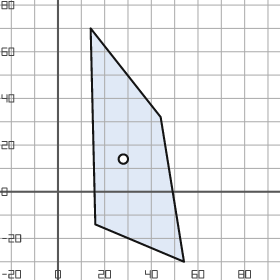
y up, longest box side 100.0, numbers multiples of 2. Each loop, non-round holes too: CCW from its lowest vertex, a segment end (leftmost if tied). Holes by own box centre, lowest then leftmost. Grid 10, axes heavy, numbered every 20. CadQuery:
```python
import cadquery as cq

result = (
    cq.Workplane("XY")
    .moveTo(54.0, -30.0)
    .lineTo(44.0, 32.0)
    .lineTo(14.0, 70.0)
    .lineTo(16.0, -14.0)
    .close()
    .moveTo(28.0, 14.0)
    .circle(2.0)
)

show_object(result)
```